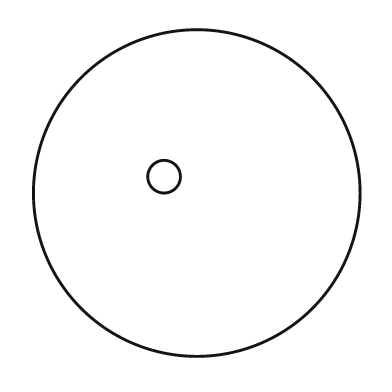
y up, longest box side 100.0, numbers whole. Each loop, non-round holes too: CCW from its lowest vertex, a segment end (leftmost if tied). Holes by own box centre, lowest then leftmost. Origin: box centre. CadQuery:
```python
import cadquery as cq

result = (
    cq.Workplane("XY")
    .moveTo(0.0, 0.0)
    .circle(50.0)
    .moveTo(-10.0, 5.0)
    .circle(5.0)
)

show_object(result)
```